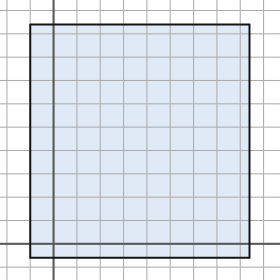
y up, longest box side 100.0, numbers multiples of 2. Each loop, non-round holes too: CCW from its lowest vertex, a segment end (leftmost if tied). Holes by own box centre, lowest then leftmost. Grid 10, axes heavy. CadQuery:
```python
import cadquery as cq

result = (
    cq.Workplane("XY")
    .moveTo(-10.0, -6.0)
    .lineTo(84.0, -6.0)
    .lineTo(84.0, 94.0)
    .lineTo(-10.0, 94.0)
    .close()
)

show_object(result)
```